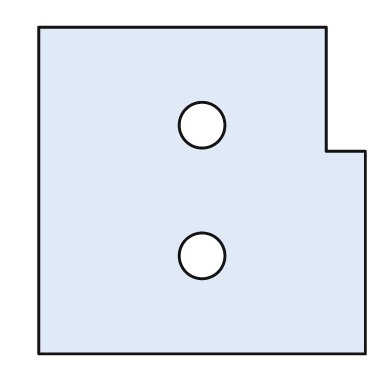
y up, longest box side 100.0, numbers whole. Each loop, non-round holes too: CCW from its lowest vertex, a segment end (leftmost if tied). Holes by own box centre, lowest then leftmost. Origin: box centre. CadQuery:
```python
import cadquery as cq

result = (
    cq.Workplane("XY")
    .moveTo(-50.0, -50.0)
    .lineTo(50.0, -50.0)
    .lineTo(50.0, 12.0)
    .lineTo(38.0, 12.0)
    .lineTo(38.0, 50.0)
    .lineTo(-50.0, 50.0)
    .close()
    .moveTo(0.0, -20.0)
    .circle(7.0)
    .moveTo(0.0, 20.0)
    .circle(7.0)
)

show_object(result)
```